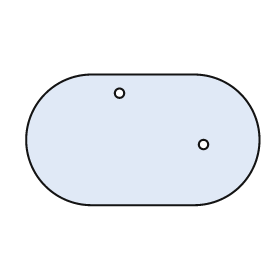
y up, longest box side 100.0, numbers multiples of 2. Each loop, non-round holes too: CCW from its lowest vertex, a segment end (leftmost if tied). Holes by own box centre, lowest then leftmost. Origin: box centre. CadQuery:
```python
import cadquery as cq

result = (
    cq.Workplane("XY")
    .moveTo(-22.0, -28.0)
    .lineTo(22.0, -28.0)
    .threePointArc((50.0, 0.0), (22.0, 28.0))
    .lineTo(-22.0, 28.0)
    .threePointArc((-50.0, 0.0), (-22.0, -28.0))
    .close()
    .moveTo(26.0, -2.0)
    .circle(2.0)
    .moveTo(-10.0, 20.0)
    .circle(2.0)
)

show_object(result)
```